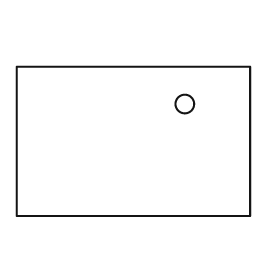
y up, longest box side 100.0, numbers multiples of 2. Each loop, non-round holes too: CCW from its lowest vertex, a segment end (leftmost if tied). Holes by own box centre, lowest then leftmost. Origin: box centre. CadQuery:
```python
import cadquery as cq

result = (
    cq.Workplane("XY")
    .moveTo(-50.0, -32.0)
    .lineTo(50.0, -32.0)
    .lineTo(50.0, 32.0)
    .lineTo(-50.0, 32.0)
    .close()
    .moveTo(22.0, 16.0)
    .circle(4.0)
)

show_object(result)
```